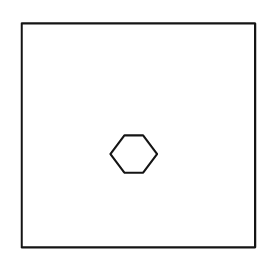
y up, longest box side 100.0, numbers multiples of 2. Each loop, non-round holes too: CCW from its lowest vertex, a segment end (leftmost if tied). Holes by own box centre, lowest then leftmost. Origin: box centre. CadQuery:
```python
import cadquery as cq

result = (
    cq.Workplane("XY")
    .moveTo(-50.0, -48.0)
    .lineTo(50.0, -48.0)
    .lineTo(50.0, 48.0)
    .lineTo(-50.0, 48.0)
    .close()
    .moveTo(-6.0, -16.0)
    .lineTo(2.0, -16.0)
    .lineTo(8.0, -8.0)
    .lineTo(2.0, 0.0)
    .lineTo(-6.0, 0.0)
    .lineTo(-12.0, -8.0)
    .close()
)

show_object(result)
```